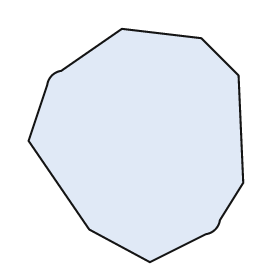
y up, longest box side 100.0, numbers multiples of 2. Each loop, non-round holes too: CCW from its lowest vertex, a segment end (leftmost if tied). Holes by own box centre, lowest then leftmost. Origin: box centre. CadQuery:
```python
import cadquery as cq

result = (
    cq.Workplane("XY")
    .moveTo(6.0, -50.0)
    .lineTo(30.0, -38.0)
    .threePointArc((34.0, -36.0), (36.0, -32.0))
    .lineTo(46.0, -16.0)
    .lineTo(44.0, 30.0)
    .lineTo(28.0, 46.0)
    .lineTo(-6.0, 50.0)
    .lineTo(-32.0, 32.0)
    .threePointArc((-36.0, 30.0), (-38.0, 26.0))
    .lineTo(-46.0, 2.0)
    .lineTo(-20.0, -36.0)
    .close()
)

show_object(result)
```